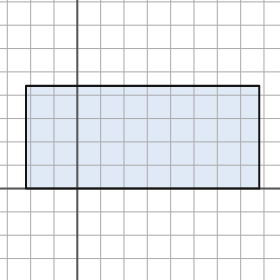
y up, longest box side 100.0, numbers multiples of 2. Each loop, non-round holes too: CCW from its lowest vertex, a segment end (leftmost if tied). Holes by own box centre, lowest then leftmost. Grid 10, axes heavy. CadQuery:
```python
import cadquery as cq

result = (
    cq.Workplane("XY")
    .moveTo(-22.0, 0.0)
    .lineTo(78.0, 0.0)
    .lineTo(78.0, 44.0)
    .lineTo(-22.0, 44.0)
    .close()
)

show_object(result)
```